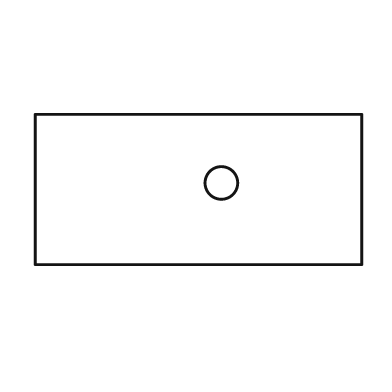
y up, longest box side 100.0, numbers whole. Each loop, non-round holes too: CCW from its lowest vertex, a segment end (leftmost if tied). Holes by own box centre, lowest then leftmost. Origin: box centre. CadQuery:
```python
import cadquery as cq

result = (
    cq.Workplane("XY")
    .moveTo(-50.0, -23.0)
    .lineTo(50.0, -23.0)
    .lineTo(50.0, 23.0)
    .lineTo(-50.0, 23.0)
    .close()
    .moveTo(7.0, 2.0)
    .circle(5.0)
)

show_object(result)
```